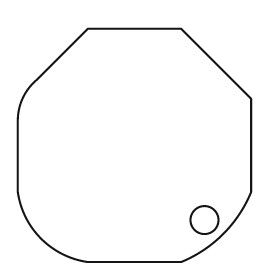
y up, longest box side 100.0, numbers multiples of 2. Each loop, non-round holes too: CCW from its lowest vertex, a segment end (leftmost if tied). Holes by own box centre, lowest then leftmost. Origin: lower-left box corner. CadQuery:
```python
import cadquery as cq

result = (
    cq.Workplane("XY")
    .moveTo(30.0, 0.0)
    .lineTo(70.0, 0.0)
    .threePointArc((88.0, 12.0), (100.0, 30.0))
    .lineTo(100.0, 70.0)
    .lineTo(70.0, 100.0)
    .lineTo(30.0, 100.0)
    .lineTo(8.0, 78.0)
    .threePointArc((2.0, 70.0), (0.0, 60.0))
    .lineTo(0.0, 30.0)
    .threePointArc((10.0, 10.0), (30.0, 0.0))
    .close()
    .moveTo(80.0, 18.0)
    .circle(6.0)
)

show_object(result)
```